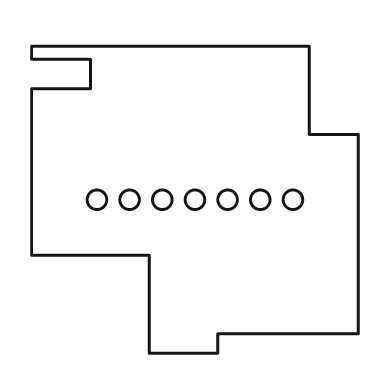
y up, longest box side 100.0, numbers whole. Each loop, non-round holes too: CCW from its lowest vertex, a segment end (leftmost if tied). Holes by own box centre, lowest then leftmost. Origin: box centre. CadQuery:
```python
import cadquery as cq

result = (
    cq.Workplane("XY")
    .moveTo(-14.0, -47.0)
    .lineTo(7.0, -47.0)
    .lineTo(7.0, -41.0)
    .lineTo(50.0, -41.0)
    .lineTo(50.0, 20.0)
    .lineTo(35.0, 20.0)
    .lineTo(35.0, 47.0)
    .lineTo(-50.0, 47.0)
    .lineTo(-50.0, 43.0)
    .lineTo(-32.0, 43.0)
    .lineTo(-32.0, 34.0)
    .lineTo(-50.0, 34.0)
    .lineTo(-50.0, -17.0)
    .lineTo(-14.0, -17.0)
    .close()
    .moveTo(-30.0, 0.0)
    .circle(3.0)
    .moveTo(-20.0, 0.0)
    .circle(3.0)
    .moveTo(-10.0, 0.0)
    .circle(3.0)
    .moveTo(0.0, 0.0)
    .circle(3.0)
    .moveTo(10.0, 0.0)
    .circle(3.0)
    .moveTo(20.0, 0.0)
    .circle(3.0)
    .moveTo(30.0, 0.0)
    .circle(3.0)
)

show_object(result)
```